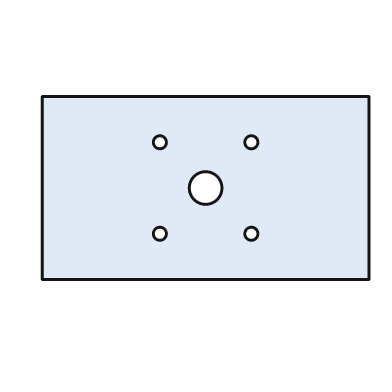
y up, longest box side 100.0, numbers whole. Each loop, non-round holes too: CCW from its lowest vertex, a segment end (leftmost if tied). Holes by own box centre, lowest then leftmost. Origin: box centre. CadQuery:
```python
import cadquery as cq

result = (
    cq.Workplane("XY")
    .moveTo(-50.0, -28.0)
    .lineTo(50.0, -28.0)
    .lineTo(50.0, 28.0)
    .lineTo(-50.0, 28.0)
    .close()
    .moveTo(-14.0, -14.0)
    .circle(2.0)
    .moveTo(14.0, -14.0)
    .circle(2.0)
    .moveTo(0.0, 0.0)
    .circle(5.0)
    .moveTo(-14.0, 14.0)
    .circle(2.0)
    .moveTo(14.0, 14.0)
    .circle(2.0)
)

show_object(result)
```